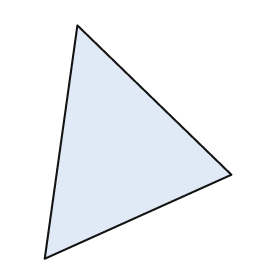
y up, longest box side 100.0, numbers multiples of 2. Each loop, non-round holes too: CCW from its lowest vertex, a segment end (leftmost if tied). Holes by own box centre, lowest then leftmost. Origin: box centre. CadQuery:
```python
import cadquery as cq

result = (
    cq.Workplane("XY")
    .moveTo(-40.0, -50.0)
    .lineTo(40.0, -14.0)
    .lineTo(-26.0, 50.0)
    .close()
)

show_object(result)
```